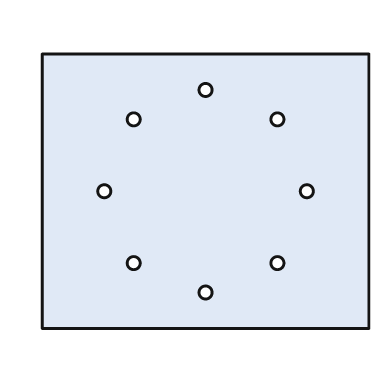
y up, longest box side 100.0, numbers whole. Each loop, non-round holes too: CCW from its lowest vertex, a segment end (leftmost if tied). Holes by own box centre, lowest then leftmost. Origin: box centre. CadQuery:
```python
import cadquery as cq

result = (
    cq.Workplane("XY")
    .moveTo(-50.0, -42.0)
    .lineTo(50.0, -42.0)
    .lineTo(50.0, 42.0)
    .lineTo(-50.0, 42.0)
    .close()
    .moveTo(0.0, -31.0)
    .circle(2.0)
    .moveTo(-22.0, -22.0)
    .circle(2.0)
    .moveTo(22.0, -22.0)
    .circle(2.0)
    .moveTo(-31.0, 0.0)
    .circle(2.0)
    .moveTo(31.0, 0.0)
    .circle(2.0)
    .moveTo(-22.0, 22.0)
    .circle(2.0)
    .moveTo(22.0, 22.0)
    .circle(2.0)
    .moveTo(0.0, 31.0)
    .circle(2.0)
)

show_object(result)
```